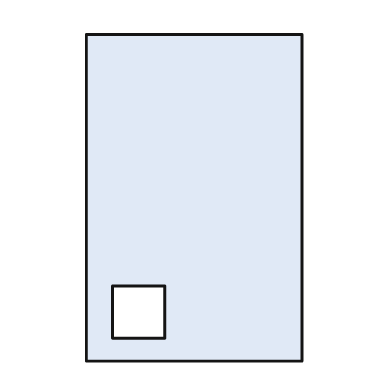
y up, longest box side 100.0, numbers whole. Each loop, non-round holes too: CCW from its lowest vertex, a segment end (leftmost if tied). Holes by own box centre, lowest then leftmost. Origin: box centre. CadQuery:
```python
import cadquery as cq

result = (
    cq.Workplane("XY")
    .moveTo(-33.0, -50.0)
    .lineTo(33.0, -50.0)
    .lineTo(33.0, 50.0)
    .lineTo(-33.0, 50.0)
    .close()
    .moveTo(-25.0, -43.0)
    .lineTo(-9.0, -43.0)
    .lineTo(-9.0, -27.0)
    .lineTo(-25.0, -27.0)
    .close()
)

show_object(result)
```